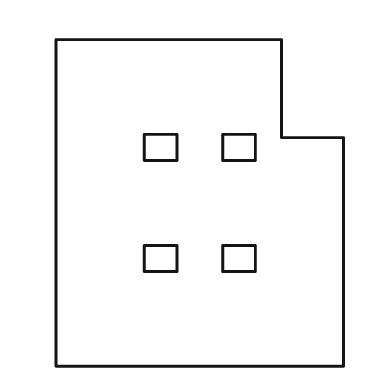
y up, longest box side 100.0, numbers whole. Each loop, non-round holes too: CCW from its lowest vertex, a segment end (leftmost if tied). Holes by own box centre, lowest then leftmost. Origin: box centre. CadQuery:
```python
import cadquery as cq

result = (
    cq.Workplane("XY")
    .moveTo(-44.0, -50.0)
    .lineTo(44.0, -50.0)
    .lineTo(44.0, 20.0)
    .lineTo(25.0, 20.0)
    .lineTo(25.0, 50.0)
    .lineTo(-44.0, 50.0)
    .close()
    .moveTo(-17.0, -21.0)
    .lineTo(-7.0, -21.0)
    .lineTo(-7.0, -13.0)
    .lineTo(-17.0, -13.0)
    .close()
    .moveTo(7.0, -21.0)
    .lineTo(17.0, -21.0)
    .lineTo(17.0, -13.0)
    .lineTo(7.0, -13.0)
    .close()
    .moveTo(-17.0, 13.0)
    .lineTo(-7.0, 13.0)
    .lineTo(-7.0, 21.0)
    .lineTo(-17.0, 21.0)
    .close()
    .moveTo(7.0, 13.0)
    .lineTo(17.0, 13.0)
    .lineTo(17.0, 21.0)
    .lineTo(7.0, 21.0)
    .close()
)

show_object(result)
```